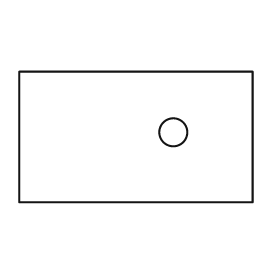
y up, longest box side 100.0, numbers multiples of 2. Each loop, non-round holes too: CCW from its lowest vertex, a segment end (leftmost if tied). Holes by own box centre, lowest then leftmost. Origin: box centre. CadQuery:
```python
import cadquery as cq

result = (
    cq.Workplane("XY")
    .moveTo(-50.0, -28.0)
    .lineTo(50.0, -28.0)
    .lineTo(50.0, 28.0)
    .lineTo(-50.0, 28.0)
    .close()
    .moveTo(16.0, 2.0)
    .circle(6.0)
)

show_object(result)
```